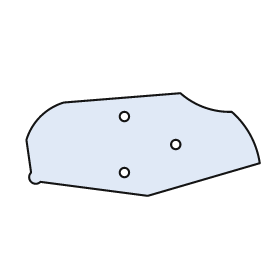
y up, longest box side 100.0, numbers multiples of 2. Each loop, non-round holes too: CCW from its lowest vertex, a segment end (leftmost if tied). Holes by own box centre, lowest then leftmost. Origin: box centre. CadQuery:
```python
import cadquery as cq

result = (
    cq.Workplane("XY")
    .moveTo(2.0, -22.0)
    .lineTo(50.0, -8.0)
    .threePointArc((46.0, 4.0), (38.0, 14.0))
    .threePointArc((26.0, 16.0), (16.0, 22.0))
    .lineTo(-34.0, 18.0)
    .threePointArc((-44.0, 12.0), (-50.0, 2.0))
    .lineTo(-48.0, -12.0)
    .threePointArc((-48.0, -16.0), (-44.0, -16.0))
    .close()
    .moveTo(-8.0, -12.0)
    .circle(2.0)
    .moveTo(14.0, 0.0)
    .circle(2.0)
    .moveTo(-8.0, 12.0)
    .circle(2.0)
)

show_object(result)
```